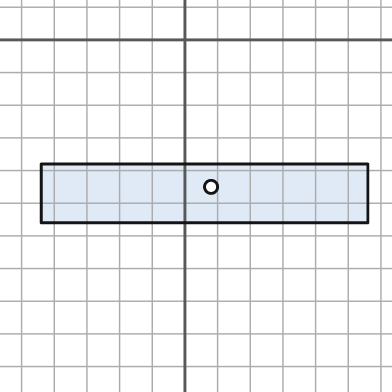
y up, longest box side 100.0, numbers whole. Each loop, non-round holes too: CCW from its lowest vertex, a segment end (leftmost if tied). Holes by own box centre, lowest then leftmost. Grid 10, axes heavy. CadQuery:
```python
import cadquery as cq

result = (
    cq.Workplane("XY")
    .moveTo(-44.0, -56.0)
    .lineTo(56.0, -56.0)
    .lineTo(56.0, -38.0)
    .lineTo(-44.0, -38.0)
    .close()
    .moveTo(8.0, -45.0)
    .circle(2.0)
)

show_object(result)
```